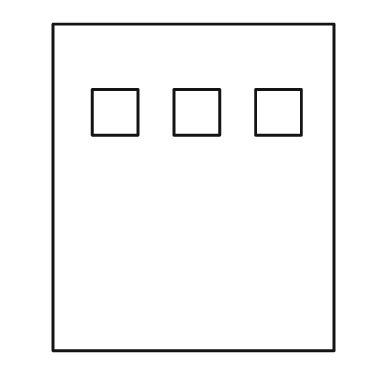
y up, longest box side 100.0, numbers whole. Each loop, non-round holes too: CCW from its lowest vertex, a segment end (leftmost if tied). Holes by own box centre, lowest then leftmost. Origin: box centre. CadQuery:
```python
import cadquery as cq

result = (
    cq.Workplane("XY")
    .moveTo(-43.0, -50.0)
    .lineTo(43.0, -50.0)
    .lineTo(43.0, 50.0)
    .lineTo(-43.0, 50.0)
    .close()
    .moveTo(-31.0, 16.0)
    .lineTo(-17.0, 16.0)
    .lineTo(-17.0, 30.0)
    .lineTo(-31.0, 30.0)
    .close()
    .moveTo(-6.0, 16.0)
    .lineTo(8.0, 16.0)
    .lineTo(8.0, 30.0)
    .lineTo(-6.0, 30.0)
    .close()
    .moveTo(19.0, 16.0)
    .lineTo(33.0, 16.0)
    .lineTo(33.0, 30.0)
    .lineTo(19.0, 30.0)
    .close()
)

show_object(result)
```